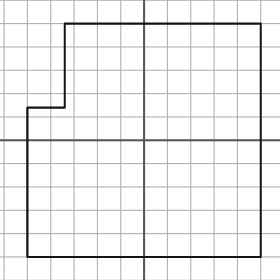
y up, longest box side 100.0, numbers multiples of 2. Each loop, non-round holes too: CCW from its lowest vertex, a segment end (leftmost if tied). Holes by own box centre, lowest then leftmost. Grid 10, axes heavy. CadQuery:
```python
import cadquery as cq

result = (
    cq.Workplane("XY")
    .moveTo(-50.0, -50.0)
    .lineTo(50.0, -50.0)
    .lineTo(50.0, 50.0)
    .lineTo(-34.0, 50.0)
    .lineTo(-34.0, 14.0)
    .lineTo(-50.0, 14.0)
    .close()
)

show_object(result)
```